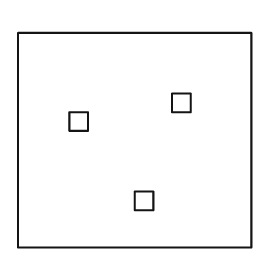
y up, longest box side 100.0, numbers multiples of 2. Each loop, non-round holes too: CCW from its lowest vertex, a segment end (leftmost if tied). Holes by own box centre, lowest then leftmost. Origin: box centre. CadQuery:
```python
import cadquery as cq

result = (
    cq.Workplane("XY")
    .moveTo(-50.0, -46.0)
    .lineTo(50.0, -46.0)
    .lineTo(50.0, 46.0)
    .lineTo(-50.0, 46.0)
    .close()
    .moveTo(0.0, -30.0)
    .lineTo(8.0, -30.0)
    .lineTo(8.0, -22.0)
    .lineTo(0.0, -22.0)
    .close()
    .moveTo(-28.0, 4.0)
    .lineTo(-20.0, 4.0)
    .lineTo(-20.0, 12.0)
    .lineTo(-28.0, 12.0)
    .close()
    .moveTo(16.0, 12.0)
    .lineTo(24.0, 12.0)
    .lineTo(24.0, 20.0)
    .lineTo(16.0, 20.0)
    .close()
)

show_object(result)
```